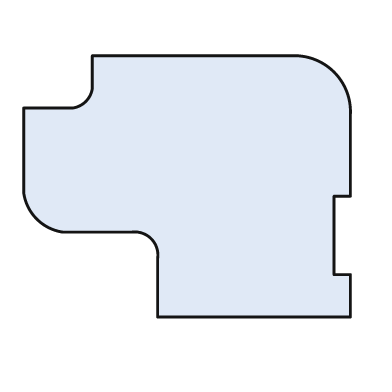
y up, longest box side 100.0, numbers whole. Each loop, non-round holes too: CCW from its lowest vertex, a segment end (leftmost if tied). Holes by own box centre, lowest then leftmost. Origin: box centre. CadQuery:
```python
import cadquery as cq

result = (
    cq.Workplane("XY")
    .moveTo(-9.0, -40.0)
    .lineTo(50.0, -40.0)
    .lineTo(50.0, -27.0)
    .lineTo(45.0, -27.0)
    .lineTo(45.0, -3.0)
    .lineTo(50.0, -3.0)
    .lineTo(50.0, 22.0)
    .threePointArc((45.0, 35.0), (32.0, 40.0))
    .lineTo(-29.0, 40.0)
    .lineTo(-29.0, 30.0)
    .threePointArc((-31.0, 26.0), (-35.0, 24.0))
    .lineTo(-50.0, 24.0)
    .lineTo(-50.0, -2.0)
    .threePointArc((-46.0, -10.0), (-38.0, -14.0))
    .lineTo(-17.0, -14.0)
    .threePointArc((-11.0, -16.0), (-9.0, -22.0))
    .close()
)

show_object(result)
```